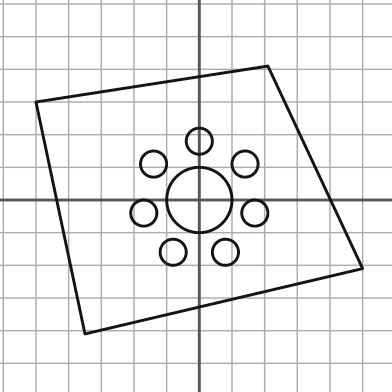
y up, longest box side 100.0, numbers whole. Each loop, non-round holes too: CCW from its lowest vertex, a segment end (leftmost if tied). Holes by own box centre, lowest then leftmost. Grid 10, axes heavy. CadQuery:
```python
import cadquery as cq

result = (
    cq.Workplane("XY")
    .moveTo(-35.0, -41.0)
    .lineTo(50.0, -21.0)
    .lineTo(21.0, 41.0)
    .lineTo(-50.0, 30.0)
    .close()
    .moveTo(-8.0, -16.0)
    .circle(4.0)
    .moveTo(8.0, -16.0)
    .circle(4.0)
    .moveTo(-17.0, -4.0)
    .circle(4.0)
    .moveTo(17.0, -4.0)
    .circle(4.0)
    .moveTo(0.0, 0.0)
    .circle(10.0)
    .moveTo(-14.0, 11.0)
    .circle(4.0)
    .moveTo(14.0, 11.0)
    .circle(4.0)
    .moveTo(0.0, 18.0)
    .circle(4.0)
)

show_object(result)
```